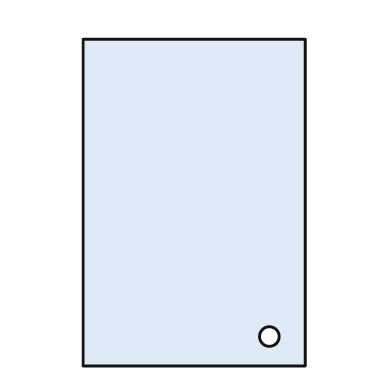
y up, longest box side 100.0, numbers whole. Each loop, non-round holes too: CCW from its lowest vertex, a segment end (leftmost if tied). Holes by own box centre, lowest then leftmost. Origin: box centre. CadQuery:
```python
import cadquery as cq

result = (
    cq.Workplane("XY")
    .moveTo(-34.0, -50.0)
    .lineTo(34.0, -50.0)
    .lineTo(34.0, 50.0)
    .lineTo(-34.0, 50.0)
    .close()
    .moveTo(23.0, -41.0)
    .circle(3.0)
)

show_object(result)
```